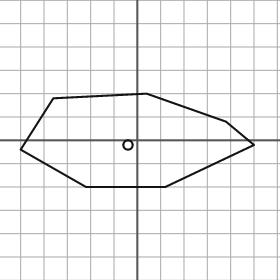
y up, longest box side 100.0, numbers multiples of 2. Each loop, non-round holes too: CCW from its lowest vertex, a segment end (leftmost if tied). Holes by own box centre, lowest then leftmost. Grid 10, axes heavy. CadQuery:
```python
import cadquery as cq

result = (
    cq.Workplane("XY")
    .moveTo(-22.0, -20.0)
    .lineTo(12.0, -20.0)
    .lineTo(50.0, -2.0)
    .lineTo(38.0, 8.0)
    .lineTo(4.0, 20.0)
    .lineTo(-36.0, 18.0)
    .lineTo(-50.0, -4.0)
    .close()
    .moveTo(-4.0, -2.0)
    .circle(2.0)
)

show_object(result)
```